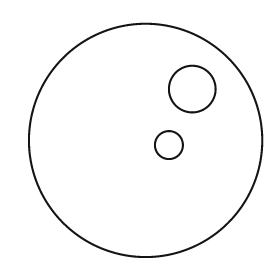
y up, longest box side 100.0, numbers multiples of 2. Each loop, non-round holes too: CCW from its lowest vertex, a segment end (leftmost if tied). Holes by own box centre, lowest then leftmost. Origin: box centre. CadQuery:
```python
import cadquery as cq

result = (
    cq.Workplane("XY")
    .moveTo(0.0, 0.0)
    .circle(50.0)
    .moveTo(10.0, -2.0)
    .circle(6.0)
    .moveTo(20.0, 22.0)
    .circle(10.0)
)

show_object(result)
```